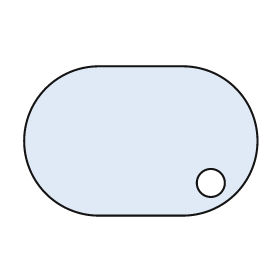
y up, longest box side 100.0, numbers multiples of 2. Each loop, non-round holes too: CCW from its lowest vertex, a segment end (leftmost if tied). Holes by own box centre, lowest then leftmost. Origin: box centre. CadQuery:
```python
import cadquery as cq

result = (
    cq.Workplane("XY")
    .moveTo(-18.0, -32.0)
    .lineTo(18.0, -32.0)
    .threePointArc((50.0, 0.0), (18.0, 32.0))
    .lineTo(-18.0, 32.0)
    .threePointArc((-50.0, 0.0), (-18.0, -32.0))
    .close()
    .moveTo(30.0, -18.0)
    .circle(6.0)
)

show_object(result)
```